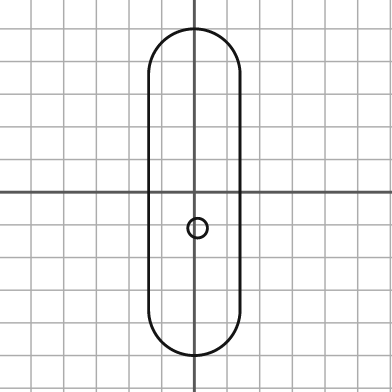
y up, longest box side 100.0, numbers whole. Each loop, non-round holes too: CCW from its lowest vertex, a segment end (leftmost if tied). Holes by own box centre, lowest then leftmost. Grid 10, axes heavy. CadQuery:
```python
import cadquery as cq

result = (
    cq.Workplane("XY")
    .moveTo(-14.0, -36.0)
    .threePointArc((0.0, -50.0), (14.0, -36.0))
    .lineTo(14.0, 36.0)
    .threePointArc((0.0, 50.0), (-14.0, 36.0))
    .close()
    .moveTo(1.0, -11.0)
    .circle(3.0)
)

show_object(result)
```